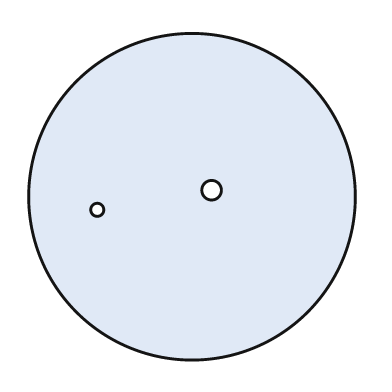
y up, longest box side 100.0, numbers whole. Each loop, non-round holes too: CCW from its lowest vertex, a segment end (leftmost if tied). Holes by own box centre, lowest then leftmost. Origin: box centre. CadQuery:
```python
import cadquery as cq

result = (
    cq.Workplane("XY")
    .moveTo(0.0, 0.0)
    .circle(50.0)
    .moveTo(-29.0, -4.0)
    .circle(2.0)
    .moveTo(6.0, 2.0)
    .circle(3.0)
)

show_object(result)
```